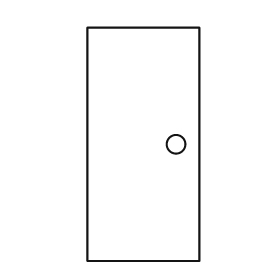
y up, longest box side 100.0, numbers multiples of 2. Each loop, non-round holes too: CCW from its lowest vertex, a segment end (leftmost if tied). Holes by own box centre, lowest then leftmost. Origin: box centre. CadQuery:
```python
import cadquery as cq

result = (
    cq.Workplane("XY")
    .moveTo(-24.0, -50.0)
    .lineTo(24.0, -50.0)
    .lineTo(24.0, 50.0)
    .lineTo(-24.0, 50.0)
    .close()
    .moveTo(14.0, 0.0)
    .circle(4.0)
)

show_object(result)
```